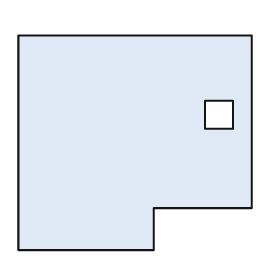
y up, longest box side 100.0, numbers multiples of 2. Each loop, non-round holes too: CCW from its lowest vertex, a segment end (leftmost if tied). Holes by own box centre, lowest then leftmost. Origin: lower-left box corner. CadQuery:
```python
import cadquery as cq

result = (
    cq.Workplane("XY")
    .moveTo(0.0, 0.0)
    .lineTo(58.0, 0.0)
    .lineTo(58.0, 18.0)
    .lineTo(100.0, 18.0)
    .lineTo(100.0, 92.0)
    .lineTo(0.0, 92.0)
    .close()
    .moveTo(80.0, 52.0)
    .lineTo(92.0, 52.0)
    .lineTo(92.0, 64.0)
    .lineTo(80.0, 64.0)
    .close()
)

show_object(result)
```